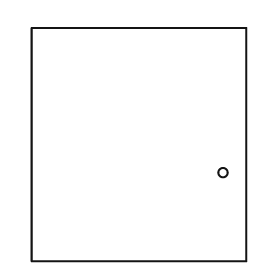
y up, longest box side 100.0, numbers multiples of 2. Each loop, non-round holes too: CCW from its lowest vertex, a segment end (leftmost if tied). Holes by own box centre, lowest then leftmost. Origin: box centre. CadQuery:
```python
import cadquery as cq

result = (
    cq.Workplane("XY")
    .moveTo(-46.0, -50.0)
    .lineTo(46.0, -50.0)
    .lineTo(46.0, 50.0)
    .lineTo(-46.0, 50.0)
    .close()
    .moveTo(36.0, -12.0)
    .circle(2.0)
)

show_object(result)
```